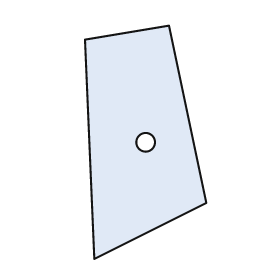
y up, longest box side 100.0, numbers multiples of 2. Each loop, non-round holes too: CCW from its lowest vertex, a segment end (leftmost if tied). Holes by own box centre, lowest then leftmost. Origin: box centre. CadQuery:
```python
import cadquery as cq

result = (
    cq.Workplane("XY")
    .moveTo(-22.0, -50.0)
    .lineTo(26.0, -26.0)
    .lineTo(10.0, 50.0)
    .lineTo(-26.0, 44.0)
    .close()
    .moveTo(0.0, 0.0)
    .circle(4.0)
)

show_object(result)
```